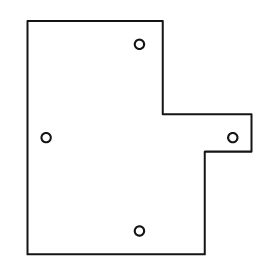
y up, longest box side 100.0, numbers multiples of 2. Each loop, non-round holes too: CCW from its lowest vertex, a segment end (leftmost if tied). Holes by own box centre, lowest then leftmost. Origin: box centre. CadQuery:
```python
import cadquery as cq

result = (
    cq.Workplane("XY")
    .moveTo(-48.0, -50.0)
    .lineTo(28.0, -50.0)
    .lineTo(28.0, -6.0)
    .lineTo(48.0, -6.0)
    .lineTo(48.0, 10.0)
    .lineTo(10.0, 10.0)
    .lineTo(10.0, 50.0)
    .lineTo(-48.0, 50.0)
    .close()
    .moveTo(0.0, -40.0)
    .circle(2.0)
    .moveTo(-40.0, 0.0)
    .circle(2.0)
    .moveTo(40.0, 0.0)
    .circle(2.0)
    .moveTo(0.0, 40.0)
    .circle(2.0)
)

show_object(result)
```